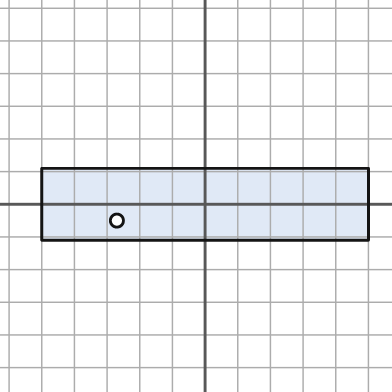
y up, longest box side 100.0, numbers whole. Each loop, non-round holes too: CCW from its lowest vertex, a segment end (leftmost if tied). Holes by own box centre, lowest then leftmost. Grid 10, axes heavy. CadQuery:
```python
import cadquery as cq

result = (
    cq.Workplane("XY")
    .moveTo(-50.0, -11.0)
    .lineTo(50.0, -11.0)
    .lineTo(50.0, 11.0)
    .lineTo(-50.0, 11.0)
    .close()
    .moveTo(-27.0, -5.0)
    .circle(2.0)
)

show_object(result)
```